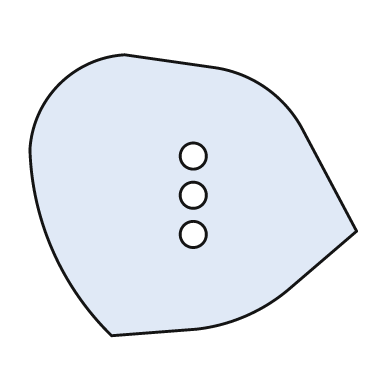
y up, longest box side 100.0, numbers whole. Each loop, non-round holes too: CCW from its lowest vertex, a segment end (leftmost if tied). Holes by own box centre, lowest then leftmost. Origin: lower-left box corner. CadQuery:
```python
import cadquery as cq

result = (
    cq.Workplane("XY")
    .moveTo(25.0, 0.0)
    .lineTo(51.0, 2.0)
    .threePointArc((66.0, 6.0), (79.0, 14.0))
    .lineTo(100.0, 32.0)
    .lineTo(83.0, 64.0)
    .threePointArc((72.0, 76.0), (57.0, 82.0))
    .lineTo(29.0, 86.0)
    .threePointArc((9.0, 77.0), (0.0, 57.0))
    .threePointArc((7.0, 26.0), (25.0, 0.0))
    .close()
    .moveTo(50.0, 31.0)
    .circle(4.0)
    .moveTo(50.0, 43.0)
    .circle(4.0)
    .moveTo(50.0, 55.0)
    .circle(4.0)
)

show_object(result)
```